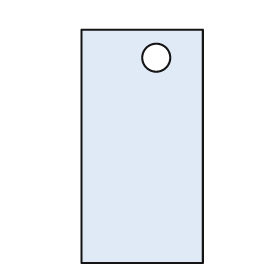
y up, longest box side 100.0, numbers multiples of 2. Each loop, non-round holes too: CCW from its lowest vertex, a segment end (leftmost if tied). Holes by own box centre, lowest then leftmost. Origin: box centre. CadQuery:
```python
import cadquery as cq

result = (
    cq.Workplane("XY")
    .moveTo(-26.0, -50.0)
    .lineTo(26.0, -50.0)
    .lineTo(26.0, 50.0)
    .lineTo(-26.0, 50.0)
    .close()
    .moveTo(6.0, 38.0)
    .circle(6.0)
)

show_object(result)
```